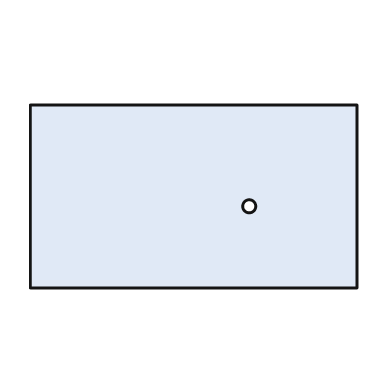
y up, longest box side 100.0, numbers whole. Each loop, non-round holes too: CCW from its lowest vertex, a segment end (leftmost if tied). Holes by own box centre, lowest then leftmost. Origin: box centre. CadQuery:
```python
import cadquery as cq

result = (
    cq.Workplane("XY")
    .moveTo(-50.0, -28.0)
    .lineTo(50.0, -28.0)
    .lineTo(50.0, 28.0)
    .lineTo(-50.0, 28.0)
    .close()
    .moveTo(17.0, -3.0)
    .circle(2.0)
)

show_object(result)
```